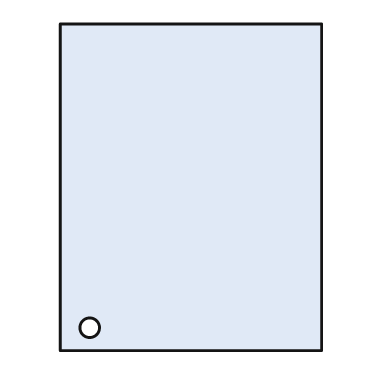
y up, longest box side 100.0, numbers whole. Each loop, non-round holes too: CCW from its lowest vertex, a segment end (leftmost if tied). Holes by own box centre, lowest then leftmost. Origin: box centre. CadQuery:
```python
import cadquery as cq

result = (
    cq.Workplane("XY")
    .moveTo(-40.0, -50.0)
    .lineTo(40.0, -50.0)
    .lineTo(40.0, 50.0)
    .lineTo(-40.0, 50.0)
    .close()
    .moveTo(-31.0, -43.0)
    .circle(3.0)
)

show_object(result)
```